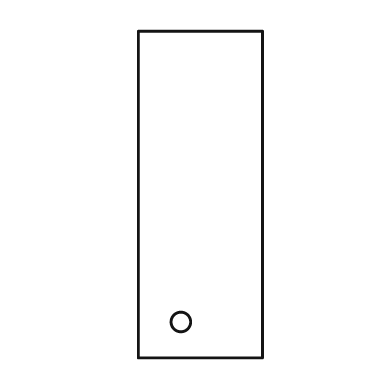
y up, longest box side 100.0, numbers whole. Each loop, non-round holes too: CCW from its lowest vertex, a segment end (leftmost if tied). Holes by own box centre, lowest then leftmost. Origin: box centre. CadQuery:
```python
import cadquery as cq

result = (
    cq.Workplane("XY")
    .moveTo(-19.0, -50.0)
    .lineTo(19.0, -50.0)
    .lineTo(19.0, 50.0)
    .lineTo(-19.0, 50.0)
    .close()
    .moveTo(-6.0, -39.0)
    .circle(3.0)
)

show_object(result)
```